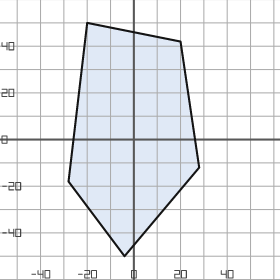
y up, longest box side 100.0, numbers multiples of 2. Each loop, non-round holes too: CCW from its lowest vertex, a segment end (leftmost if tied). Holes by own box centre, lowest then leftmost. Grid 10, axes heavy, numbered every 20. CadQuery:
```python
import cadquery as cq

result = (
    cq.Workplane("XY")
    .moveTo(-4.0, -50.0)
    .lineTo(28.0, -12.0)
    .lineTo(20.0, 42.0)
    .lineTo(-20.0, 50.0)
    .lineTo(-28.0, -18.0)
    .close()
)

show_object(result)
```